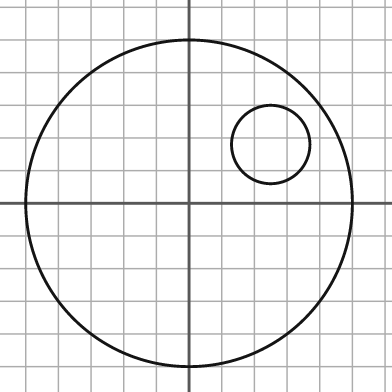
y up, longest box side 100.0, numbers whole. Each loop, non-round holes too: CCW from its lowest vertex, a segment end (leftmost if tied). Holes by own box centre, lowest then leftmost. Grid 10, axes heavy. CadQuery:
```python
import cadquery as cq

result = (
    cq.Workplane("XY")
    .moveTo(0.0, 0.0)
    .circle(50.0)
    .moveTo(25.0, 18.0)
    .circle(12.0)
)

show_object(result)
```